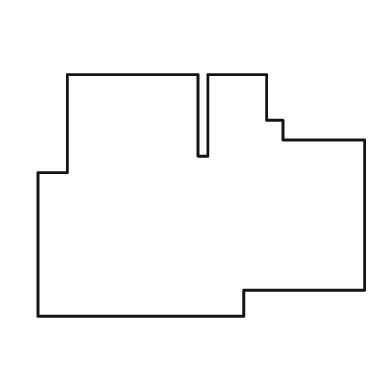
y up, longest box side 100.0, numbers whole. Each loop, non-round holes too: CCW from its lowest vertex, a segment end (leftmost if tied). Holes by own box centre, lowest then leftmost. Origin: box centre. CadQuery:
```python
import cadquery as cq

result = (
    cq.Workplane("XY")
    .moveTo(-50.0, -37.0)
    .lineTo(13.0, -37.0)
    .lineTo(13.0, -29.0)
    .lineTo(50.0, -29.0)
    .lineTo(50.0, 17.0)
    .lineTo(25.0, 17.0)
    .lineTo(25.0, 23.0)
    .lineTo(20.0, 23.0)
    .lineTo(20.0, 37.0)
    .lineTo(2.0, 37.0)
    .lineTo(2.0, 12.0)
    .lineTo(-1.0, 12.0)
    .lineTo(-1.0, 37.0)
    .lineTo(-41.0, 37.0)
    .lineTo(-41.0, 7.0)
    .lineTo(-50.0, 7.0)
    .close()
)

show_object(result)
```